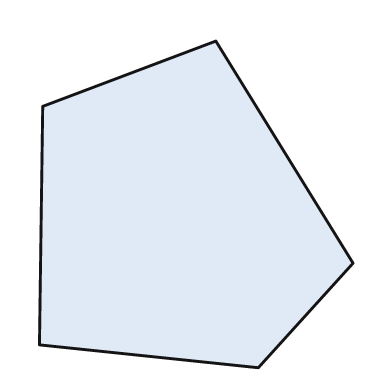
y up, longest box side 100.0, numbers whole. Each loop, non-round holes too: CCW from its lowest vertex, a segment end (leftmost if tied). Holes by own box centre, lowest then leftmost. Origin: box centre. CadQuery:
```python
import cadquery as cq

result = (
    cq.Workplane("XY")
    .moveTo(19.0, -50.0)
    .lineTo(48.0, -18.0)
    .lineTo(6.0, 50.0)
    .lineTo(-47.0, 30.0)
    .lineTo(-48.0, -43.0)
    .close()
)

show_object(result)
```